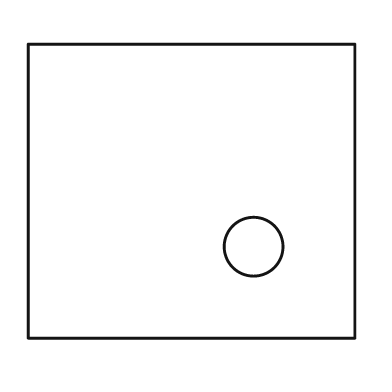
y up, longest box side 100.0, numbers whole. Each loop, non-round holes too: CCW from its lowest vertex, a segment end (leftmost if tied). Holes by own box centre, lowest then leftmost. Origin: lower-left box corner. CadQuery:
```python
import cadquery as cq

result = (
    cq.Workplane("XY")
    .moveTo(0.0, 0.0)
    .lineTo(100.0, 0.0)
    .lineTo(100.0, 90.0)
    .lineTo(0.0, 90.0)
    .close()
    .moveTo(69.0, 28.0)
    .circle(9.0)
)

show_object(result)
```